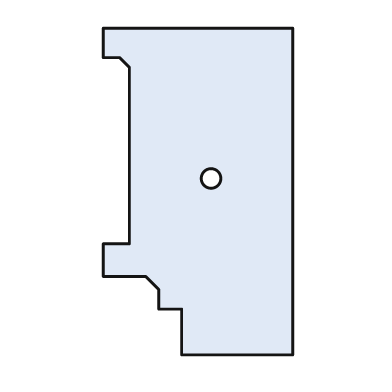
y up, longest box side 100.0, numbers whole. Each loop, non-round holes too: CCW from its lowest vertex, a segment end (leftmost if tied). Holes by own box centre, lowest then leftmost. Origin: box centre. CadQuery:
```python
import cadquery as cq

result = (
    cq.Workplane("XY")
    .moveTo(-5.0, -50.0)
    .lineTo(29.0, -50.0)
    .lineTo(29.0, 50.0)
    .lineTo(-29.0, 50.0)
    .lineTo(-29.0, 41.0)
    .lineTo(-24.0, 41.0)
    .lineTo(-21.0, 38.0)
    .lineTo(-21.0, -16.0)
    .lineTo(-29.0, -16.0)
    .lineTo(-29.0, -26.0)
    .lineTo(-16.0, -26.0)
    .lineTo(-12.0, -30.0)
    .lineTo(-12.0, -36.0)
    .lineTo(-5.0, -36.0)
    .close()
    .moveTo(4.0, 4.0)
    .circle(3.0)
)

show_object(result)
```